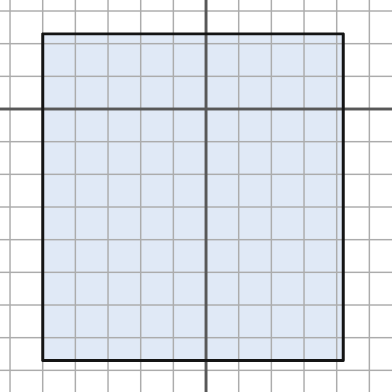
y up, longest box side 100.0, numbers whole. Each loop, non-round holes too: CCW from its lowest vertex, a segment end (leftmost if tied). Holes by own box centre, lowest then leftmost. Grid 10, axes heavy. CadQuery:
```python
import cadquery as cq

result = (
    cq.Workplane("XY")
    .moveTo(-50.0, -77.0)
    .lineTo(42.0, -77.0)
    .lineTo(42.0, 23.0)
    .lineTo(-50.0, 23.0)
    .close()
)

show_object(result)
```